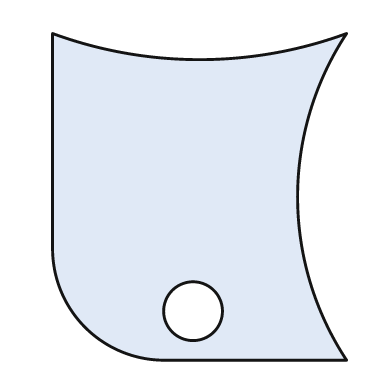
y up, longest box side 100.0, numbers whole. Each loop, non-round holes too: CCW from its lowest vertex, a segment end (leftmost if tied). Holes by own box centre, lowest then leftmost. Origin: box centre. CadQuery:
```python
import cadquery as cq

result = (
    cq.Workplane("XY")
    .moveTo(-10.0, -50.0)
    .lineTo(45.0, -50.0)
    .threePointArc((30.0, 0.0), (45.0, 50.0))
    .threePointArc((0.0, 42.0), (-45.0, 50.0))
    .lineTo(-45.0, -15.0)
    .threePointArc((-35.0, -40.0), (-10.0, -50.0))
    .close()
    .moveTo(-2.0, -35.0)
    .circle(9.0)
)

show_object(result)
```